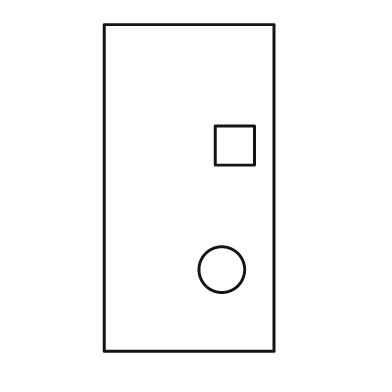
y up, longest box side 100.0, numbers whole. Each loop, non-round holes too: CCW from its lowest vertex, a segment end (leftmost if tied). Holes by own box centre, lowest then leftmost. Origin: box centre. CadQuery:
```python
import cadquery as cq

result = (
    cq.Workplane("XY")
    .moveTo(-26.0, -50.0)
    .lineTo(26.0, -50.0)
    .lineTo(26.0, 50.0)
    .lineTo(-26.0, 50.0)
    .close()
    .moveTo(10.0, -25.0)
    .circle(7.0)
    .moveTo(8.0, 7.0)
    .lineTo(20.0, 7.0)
    .lineTo(20.0, 19.0)
    .lineTo(8.0, 19.0)
    .close()
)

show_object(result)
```